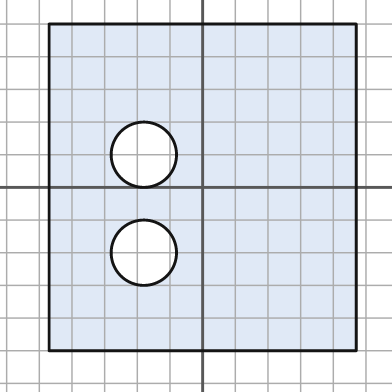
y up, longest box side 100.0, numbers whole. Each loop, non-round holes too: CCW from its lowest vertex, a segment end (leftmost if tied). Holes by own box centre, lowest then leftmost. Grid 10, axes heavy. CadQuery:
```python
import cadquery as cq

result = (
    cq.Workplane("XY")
    .moveTo(-47.0, -50.0)
    .lineTo(47.0, -50.0)
    .lineTo(47.0, 50.0)
    .lineTo(-47.0, 50.0)
    .close()
    .moveTo(-18.0, -20.0)
    .circle(10.0)
    .moveTo(-18.0, 10.0)
    .circle(10.0)
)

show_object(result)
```